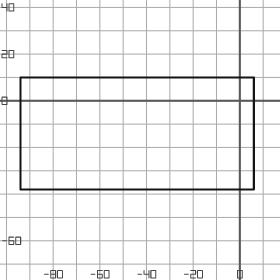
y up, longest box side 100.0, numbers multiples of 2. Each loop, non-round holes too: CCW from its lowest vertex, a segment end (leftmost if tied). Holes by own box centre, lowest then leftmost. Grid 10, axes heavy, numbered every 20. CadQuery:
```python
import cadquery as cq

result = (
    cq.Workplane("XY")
    .moveTo(-94.0, -38.0)
    .lineTo(6.0, -38.0)
    .lineTo(6.0, 10.0)
    .lineTo(-94.0, 10.0)
    .close()
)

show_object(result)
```